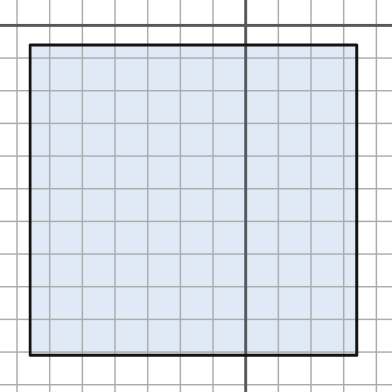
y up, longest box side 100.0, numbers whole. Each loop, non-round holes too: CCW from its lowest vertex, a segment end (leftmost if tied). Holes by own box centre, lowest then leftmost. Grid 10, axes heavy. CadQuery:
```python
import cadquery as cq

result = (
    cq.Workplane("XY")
    .moveTo(-66.0, -101.0)
    .lineTo(34.0, -101.0)
    .lineTo(34.0, -6.0)
    .lineTo(-66.0, -6.0)
    .close()
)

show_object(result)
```